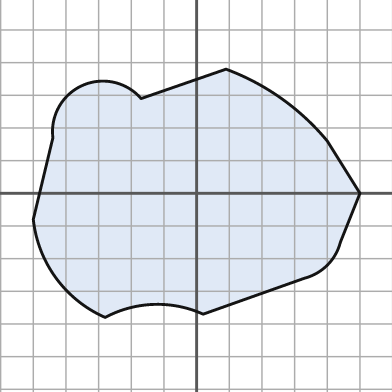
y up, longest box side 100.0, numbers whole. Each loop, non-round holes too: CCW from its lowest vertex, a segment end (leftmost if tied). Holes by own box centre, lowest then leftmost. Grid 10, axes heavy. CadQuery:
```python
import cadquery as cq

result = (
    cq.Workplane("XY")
    .moveTo(-28.0, -38.0)
    .threePointArc((-13.0, -34.0), (2.0, -37.0))
    .lineTo(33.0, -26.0)
    .threePointArc((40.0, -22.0), (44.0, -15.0))
    .lineTo(50.0, 0.0)
    .lineTo(40.0, 16.0)
    .threePointArc((26.0, 29.0), (9.0, 38.0))
    .lineTo(-17.0, 29.0)
    .threePointArc((-35.0, 33.0), (-44.0, 17.0))
    .lineTo(-50.0, -8.0)
    .threePointArc((-43.0, -26.0), (-28.0, -38.0))
    .close()
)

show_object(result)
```